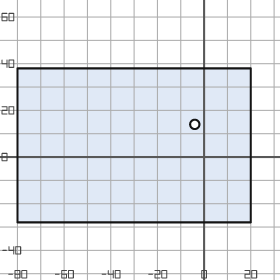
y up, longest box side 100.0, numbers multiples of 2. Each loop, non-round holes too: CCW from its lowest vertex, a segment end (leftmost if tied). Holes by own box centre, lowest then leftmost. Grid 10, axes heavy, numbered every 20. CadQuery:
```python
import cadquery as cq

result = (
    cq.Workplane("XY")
    .moveTo(-80.0, -28.0)
    .lineTo(20.0, -28.0)
    .lineTo(20.0, 38.0)
    .lineTo(-80.0, 38.0)
    .close()
    .moveTo(-4.0, 14.0)
    .circle(2.0)
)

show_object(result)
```